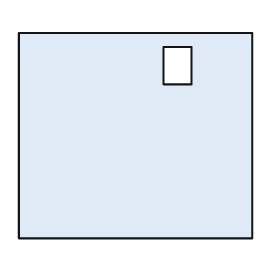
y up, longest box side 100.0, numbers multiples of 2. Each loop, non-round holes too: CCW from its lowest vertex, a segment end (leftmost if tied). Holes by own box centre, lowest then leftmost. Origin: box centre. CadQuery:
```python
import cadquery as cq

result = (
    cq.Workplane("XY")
    .moveTo(-50.0, -44.0)
    .lineTo(50.0, -44.0)
    .lineTo(50.0, 44.0)
    .lineTo(-50.0, 44.0)
    .close()
    .moveTo(12.0, 22.0)
    .lineTo(24.0, 22.0)
    .lineTo(24.0, 38.0)
    .lineTo(12.0, 38.0)
    .close()
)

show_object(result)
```